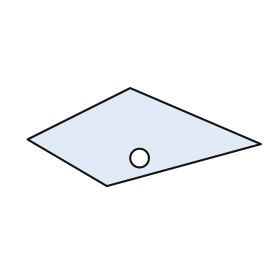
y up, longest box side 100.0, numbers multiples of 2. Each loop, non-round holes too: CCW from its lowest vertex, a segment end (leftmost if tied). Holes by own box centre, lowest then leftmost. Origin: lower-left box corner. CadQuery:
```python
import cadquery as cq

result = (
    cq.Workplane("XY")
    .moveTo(34.0, 0.0)
    .lineTo(100.0, 18.0)
    .lineTo(44.0, 42.0)
    .lineTo(0.0, 20.0)
    .close()
    .moveTo(48.0, 12.0)
    .circle(4.0)
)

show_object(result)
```